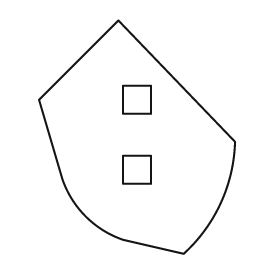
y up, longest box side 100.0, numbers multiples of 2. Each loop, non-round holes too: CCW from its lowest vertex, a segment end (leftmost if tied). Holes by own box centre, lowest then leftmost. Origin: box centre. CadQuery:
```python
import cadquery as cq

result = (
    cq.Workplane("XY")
    .moveTo(20.0, -50.0)
    .threePointArc((36.0, -28.0), (42.0, -2.0))
    .lineTo(-8.0, 50.0)
    .lineTo(-42.0, 16.0)
    .lineTo(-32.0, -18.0)
    .threePointArc((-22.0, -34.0), (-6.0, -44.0))
    .close()
    .moveTo(-6.0, -20.0)
    .lineTo(6.0, -20.0)
    .lineTo(6.0, -8.0)
    .lineTo(-6.0, -8.0)
    .close()
    .moveTo(-6.0, 10.0)
    .lineTo(6.0, 10.0)
    .lineTo(6.0, 22.0)
    .lineTo(-6.0, 22.0)
    .close()
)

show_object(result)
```